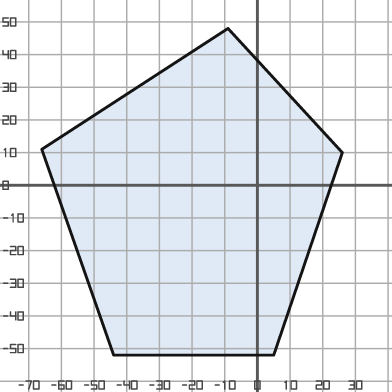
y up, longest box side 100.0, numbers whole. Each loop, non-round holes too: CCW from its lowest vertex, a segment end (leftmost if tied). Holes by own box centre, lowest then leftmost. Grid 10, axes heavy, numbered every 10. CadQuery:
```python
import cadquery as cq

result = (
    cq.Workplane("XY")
    .moveTo(-44.0, -52.0)
    .lineTo(5.0, -52.0)
    .lineTo(26.0, 10.0)
    .lineTo(-9.0, 48.0)
    .lineTo(-66.0, 11.0)
    .close()
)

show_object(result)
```